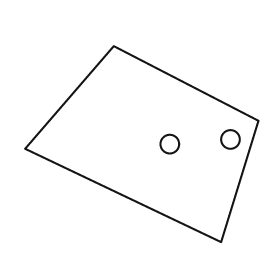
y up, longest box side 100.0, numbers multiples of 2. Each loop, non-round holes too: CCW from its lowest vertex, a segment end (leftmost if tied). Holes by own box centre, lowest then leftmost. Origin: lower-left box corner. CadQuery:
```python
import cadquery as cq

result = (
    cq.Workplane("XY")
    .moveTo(84.0, 0.0)
    .lineTo(100.0, 52.0)
    .lineTo(38.0, 84.0)
    .lineTo(0.0, 40.0)
    .close()
    .moveTo(62.0, 42.0)
    .circle(4.0)
    .moveTo(88.0, 44.0)
    .circle(4.0)
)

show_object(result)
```